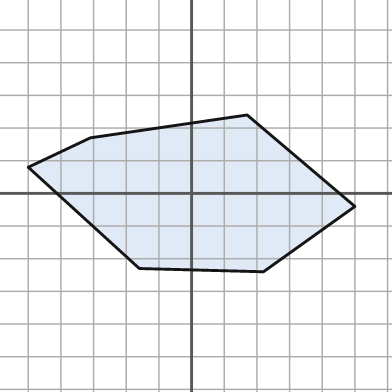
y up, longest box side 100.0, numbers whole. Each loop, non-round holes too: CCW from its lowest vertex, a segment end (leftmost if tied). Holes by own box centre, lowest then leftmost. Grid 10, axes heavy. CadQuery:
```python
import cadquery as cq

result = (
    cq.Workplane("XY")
    .moveTo(22.0, -24.0)
    .lineTo(50.0, -4.0)
    .lineTo(17.0, 24.0)
    .lineTo(-31.0, 17.0)
    .lineTo(-50.0, 8.0)
    .lineTo(-16.0, -23.0)
    .close()
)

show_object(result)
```